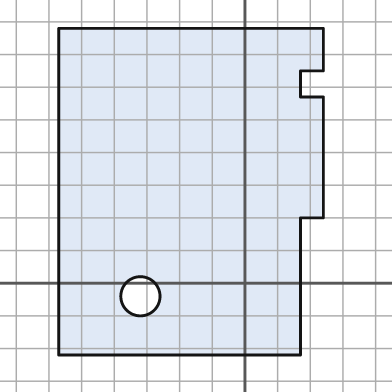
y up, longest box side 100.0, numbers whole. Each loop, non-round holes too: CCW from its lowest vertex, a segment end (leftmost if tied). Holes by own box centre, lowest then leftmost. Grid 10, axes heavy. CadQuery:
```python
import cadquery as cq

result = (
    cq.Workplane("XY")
    .moveTo(-57.0, -22.0)
    .lineTo(17.0, -22.0)
    .lineTo(17.0, 20.0)
    .lineTo(24.0, 20.0)
    .lineTo(24.0, 57.0)
    .lineTo(17.0, 57.0)
    .lineTo(17.0, 65.0)
    .lineTo(24.0, 65.0)
    .lineTo(24.0, 78.0)
    .lineTo(-57.0, 78.0)
    .close()
    .moveTo(-32.0, -4.0)
    .circle(6.0)
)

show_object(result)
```